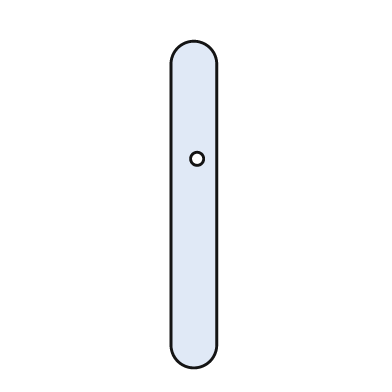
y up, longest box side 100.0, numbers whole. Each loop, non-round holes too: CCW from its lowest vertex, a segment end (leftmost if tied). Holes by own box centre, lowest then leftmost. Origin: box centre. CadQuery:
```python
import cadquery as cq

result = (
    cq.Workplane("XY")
    .moveTo(-7.0, -43.0)
    .threePointArc((0.0, -50.0), (7.0, -43.0))
    .lineTo(7.0, 43.0)
    .threePointArc((0.0, 50.0), (-7.0, 43.0))
    .close()
    .moveTo(1.0, 14.0)
    .circle(2.0)
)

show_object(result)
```